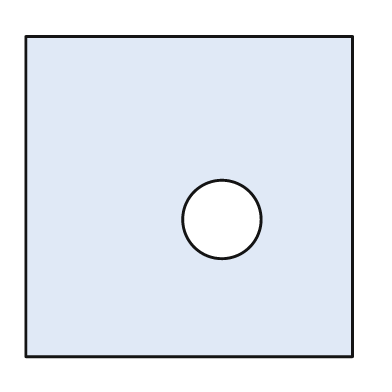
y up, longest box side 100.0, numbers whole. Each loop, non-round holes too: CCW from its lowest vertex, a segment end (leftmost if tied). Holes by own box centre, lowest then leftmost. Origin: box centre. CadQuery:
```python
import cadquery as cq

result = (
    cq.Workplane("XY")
    .moveTo(-50.0, -49.0)
    .lineTo(50.0, -49.0)
    .lineTo(50.0, 49.0)
    .lineTo(-50.0, 49.0)
    .close()
    .moveTo(10.0, -7.0)
    .circle(12.0)
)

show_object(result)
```